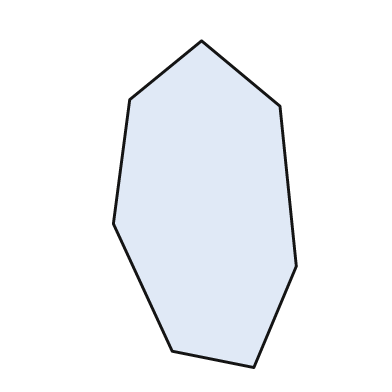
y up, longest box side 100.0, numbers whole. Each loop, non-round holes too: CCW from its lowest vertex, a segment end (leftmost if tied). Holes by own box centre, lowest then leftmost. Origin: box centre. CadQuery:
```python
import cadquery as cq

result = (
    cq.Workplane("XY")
    .moveTo(15.0, -50.0)
    .lineTo(28.0, -19.0)
    .lineTo(23.0, 30.0)
    .lineTo(-1.0, 50.0)
    .lineTo(-23.0, 32.0)
    .lineTo(-28.0, -6.0)
    .lineTo(-10.0, -45.0)
    .close()
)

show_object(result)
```